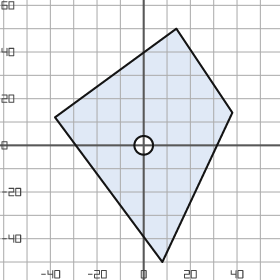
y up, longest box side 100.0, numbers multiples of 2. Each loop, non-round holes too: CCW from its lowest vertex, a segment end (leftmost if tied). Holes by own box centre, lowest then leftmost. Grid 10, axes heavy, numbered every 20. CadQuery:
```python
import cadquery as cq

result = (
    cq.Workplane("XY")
    .moveTo(8.0, -50.0)
    .lineTo(38.0, 14.0)
    .lineTo(14.0, 50.0)
    .lineTo(-38.0, 12.0)
    .close()
    .moveTo(0.0, 0.0)
    .circle(4.0)
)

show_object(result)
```